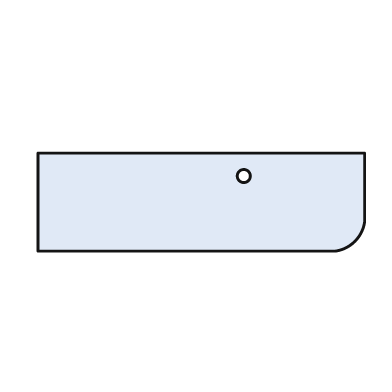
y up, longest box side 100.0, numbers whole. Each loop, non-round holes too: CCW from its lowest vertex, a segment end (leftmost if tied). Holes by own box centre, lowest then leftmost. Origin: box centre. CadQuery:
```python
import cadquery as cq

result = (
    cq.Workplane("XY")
    .moveTo(-50.0, -15.0)
    .lineTo(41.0, -15.0)
    .threePointArc((47.0, -12.0), (50.0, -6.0))
    .lineTo(50.0, 15.0)
    .lineTo(-50.0, 15.0)
    .close()
    .moveTo(13.0, 8.0)
    .circle(2.0)
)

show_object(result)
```